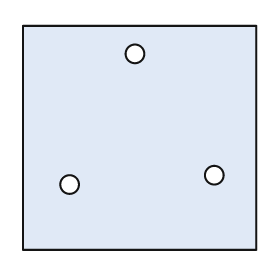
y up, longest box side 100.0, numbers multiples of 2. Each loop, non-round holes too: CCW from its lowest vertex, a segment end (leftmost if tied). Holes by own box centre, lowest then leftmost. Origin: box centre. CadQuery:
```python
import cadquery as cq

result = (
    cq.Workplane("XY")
    .moveTo(-50.0, -48.0)
    .lineTo(50.0, -48.0)
    .lineTo(50.0, 48.0)
    .lineTo(-50.0, 48.0)
    .close()
    .moveTo(-30.0, -20.0)
    .circle(4.0)
    .moveTo(32.0, -16.0)
    .circle(4.0)
    .moveTo(-2.0, 36.0)
    .circle(4.0)
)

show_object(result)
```